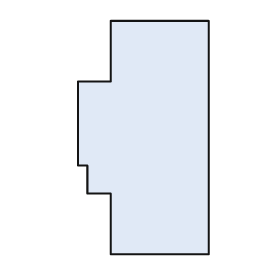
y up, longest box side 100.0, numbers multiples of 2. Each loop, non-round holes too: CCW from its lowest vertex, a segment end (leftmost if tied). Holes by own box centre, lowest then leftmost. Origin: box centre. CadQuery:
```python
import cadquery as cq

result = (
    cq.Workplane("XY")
    .moveTo(-14.0, -50.0)
    .lineTo(28.0, -50.0)
    .lineTo(28.0, 50.0)
    .lineTo(-14.0, 50.0)
    .lineTo(-14.0, 24.0)
    .lineTo(-28.0, 24.0)
    .lineTo(-28.0, -12.0)
    .lineTo(-24.0, -12.0)
    .lineTo(-24.0, -24.0)
    .lineTo(-14.0, -24.0)
    .close()
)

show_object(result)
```